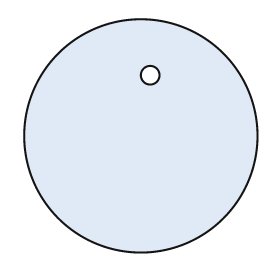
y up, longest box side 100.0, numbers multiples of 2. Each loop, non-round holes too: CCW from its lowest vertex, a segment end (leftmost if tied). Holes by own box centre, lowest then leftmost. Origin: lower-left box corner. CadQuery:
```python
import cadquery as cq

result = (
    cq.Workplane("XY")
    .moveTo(50.0, 50.0)
    .circle(50.0)
    .moveTo(54.0, 76.0)
    .circle(4.0)
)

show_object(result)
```